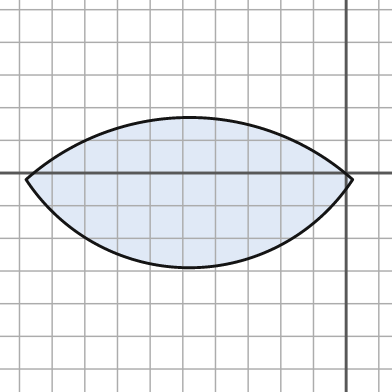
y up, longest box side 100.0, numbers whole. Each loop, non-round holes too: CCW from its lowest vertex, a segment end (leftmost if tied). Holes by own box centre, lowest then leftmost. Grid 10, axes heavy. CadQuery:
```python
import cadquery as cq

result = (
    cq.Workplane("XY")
    .moveTo(-98.0, -2.0)
    .threePointArc((-48.0, -29.0), (2.0, -2.0))
    .threePointArc((-48.0, 17.0), (-98.0, -2.0))
    .close()
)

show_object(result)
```